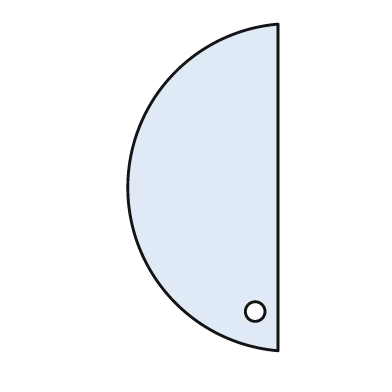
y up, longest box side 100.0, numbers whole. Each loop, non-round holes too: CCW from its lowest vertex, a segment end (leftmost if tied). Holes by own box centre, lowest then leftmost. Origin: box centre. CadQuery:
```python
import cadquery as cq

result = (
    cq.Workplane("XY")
    .moveTo(23.0, -50.0)
    .lineTo(23.0, 50.0)
    .threePointArc((-23.0, 0.0), (23.0, -50.0))
    .close()
    .moveTo(16.0, -38.0)
    .circle(3.0)
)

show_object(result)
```